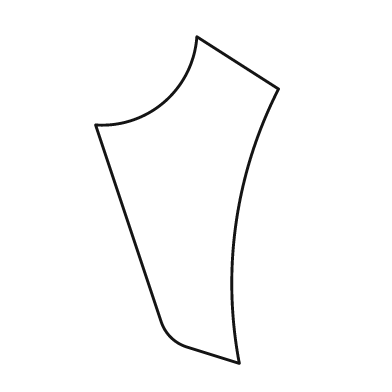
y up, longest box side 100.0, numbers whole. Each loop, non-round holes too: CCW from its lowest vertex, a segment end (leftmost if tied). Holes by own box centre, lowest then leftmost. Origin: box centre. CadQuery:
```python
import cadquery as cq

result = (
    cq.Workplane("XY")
    .moveTo(16.0, -50.0)
    .threePointArc((15.0, -7.0), (28.0, 34.0))
    .lineTo(3.0, 50.0)
    .threePointArc((-7.0, 30.0), (-28.0, 23.0))
    .lineTo(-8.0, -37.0)
    .threePointArc((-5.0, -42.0), (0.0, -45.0))
    .close()
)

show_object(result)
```